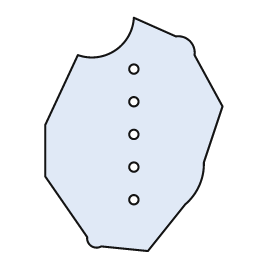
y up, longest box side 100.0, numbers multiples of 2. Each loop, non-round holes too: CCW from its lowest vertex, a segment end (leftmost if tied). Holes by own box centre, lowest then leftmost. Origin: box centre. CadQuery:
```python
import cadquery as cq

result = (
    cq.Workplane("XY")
    .moveTo(6.0, -50.0)
    .lineTo(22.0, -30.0)
    .threePointArc((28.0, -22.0), (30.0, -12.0))
    .lineTo(38.0, 12.0)
    .lineTo(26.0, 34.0)
    .threePointArc((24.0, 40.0), (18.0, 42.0))
    .lineTo(0.0, 50.0)
    .threePointArc((-8.0, 36.0), (-24.0, 34.0))
    .lineTo(-38.0, 4.0)
    .lineTo(-38.0, -18.0)
    .lineTo(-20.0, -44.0)
    .threePointArc((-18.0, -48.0), (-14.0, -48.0))
    .close()
    .moveTo(0.0, -28.0)
    .circle(2.0)
    .moveTo(0.0, -14.0)
    .circle(2.0)
    .moveTo(0.0, 0.0)
    .circle(2.0)
    .moveTo(0.0, 14.0)
    .circle(2.0)
    .moveTo(0.0, 28.0)
    .circle(2.0)
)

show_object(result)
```